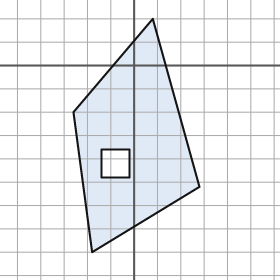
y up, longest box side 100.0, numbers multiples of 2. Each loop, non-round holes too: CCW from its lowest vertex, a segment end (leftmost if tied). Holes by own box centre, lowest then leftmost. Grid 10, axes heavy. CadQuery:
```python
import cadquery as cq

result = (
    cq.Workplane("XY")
    .moveTo(-18.0, -80.0)
    .lineTo(28.0, -52.0)
    .lineTo(8.0, 20.0)
    .lineTo(-26.0, -20.0)
    .close()
    .moveTo(-14.0, -48.0)
    .lineTo(-2.0, -48.0)
    .lineTo(-2.0, -36.0)
    .lineTo(-14.0, -36.0)
    .close()
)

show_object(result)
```